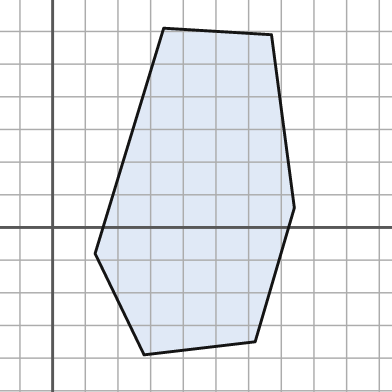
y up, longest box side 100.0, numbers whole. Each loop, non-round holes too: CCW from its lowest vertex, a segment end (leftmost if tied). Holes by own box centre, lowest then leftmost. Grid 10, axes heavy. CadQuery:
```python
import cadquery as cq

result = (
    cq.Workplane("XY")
    .moveTo(28.0, -39.0)
    .lineTo(62.0, -35.0)
    .lineTo(74.0, 6.0)
    .lineTo(67.0, 59.0)
    .lineTo(34.0, 61.0)
    .lineTo(13.0, -8.0)
    .close()
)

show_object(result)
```